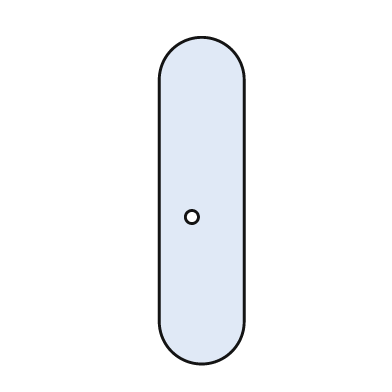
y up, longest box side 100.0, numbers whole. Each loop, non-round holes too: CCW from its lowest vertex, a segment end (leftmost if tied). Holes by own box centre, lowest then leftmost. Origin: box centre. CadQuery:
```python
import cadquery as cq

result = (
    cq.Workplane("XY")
    .moveTo(-13.0, -37.0)
    .threePointArc((0.0, -50.0), (13.0, -37.0))
    .lineTo(13.0, 37.0)
    .threePointArc((0.0, 50.0), (-13.0, 37.0))
    .close()
    .moveTo(-3.0, -5.0)
    .circle(2.0)
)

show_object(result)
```